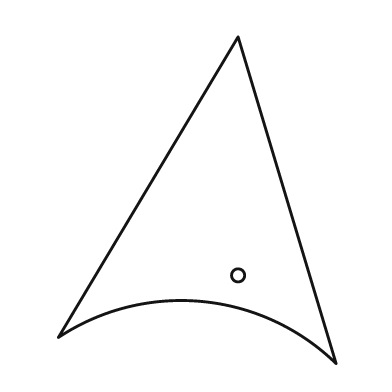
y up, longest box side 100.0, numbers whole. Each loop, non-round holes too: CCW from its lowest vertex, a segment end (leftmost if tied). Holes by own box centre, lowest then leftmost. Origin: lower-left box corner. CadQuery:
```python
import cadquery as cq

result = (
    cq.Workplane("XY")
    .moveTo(85.0, 0.0)
    .lineTo(55.0, 100.0)
    .lineTo(0.0, 8.0)
    .threePointArc((44.0, 19.0), (85.0, 0.0))
    .close()
    .moveTo(55.0, 27.0)
    .circle(2.0)
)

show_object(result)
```